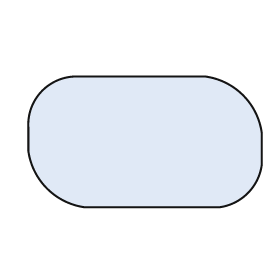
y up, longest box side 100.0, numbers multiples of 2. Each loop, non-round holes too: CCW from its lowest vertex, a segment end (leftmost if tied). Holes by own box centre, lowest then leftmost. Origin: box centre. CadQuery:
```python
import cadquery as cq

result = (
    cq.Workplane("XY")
    .moveTo(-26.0, -28.0)
    .lineTo(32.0, -28.0)
    .threePointArc((44.0, -22.0), (50.0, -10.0))
    .lineTo(50.0, 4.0)
    .threePointArc((42.0, 20.0), (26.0, 28.0))
    .lineTo(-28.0, 28.0)
    .threePointArc((-44.0, 22.0), (-50.0, 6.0))
    .lineTo(-50.0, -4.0)
    .threePointArc((-42.0, -20.0), (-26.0, -28.0))
    .close()
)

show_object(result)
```